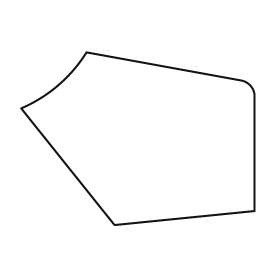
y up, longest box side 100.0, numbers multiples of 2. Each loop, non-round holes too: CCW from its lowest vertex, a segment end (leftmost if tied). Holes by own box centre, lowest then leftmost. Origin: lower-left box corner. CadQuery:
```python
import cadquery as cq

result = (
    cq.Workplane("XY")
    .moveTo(40.0, 0.0)
    .lineTo(100.0, 6.0)
    .lineTo(100.0, 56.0)
    .threePointArc((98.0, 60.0), (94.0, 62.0))
    .lineTo(28.0, 74.0)
    .threePointArc((16.0, 60.0), (0.0, 50.0))
    .close()
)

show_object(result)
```